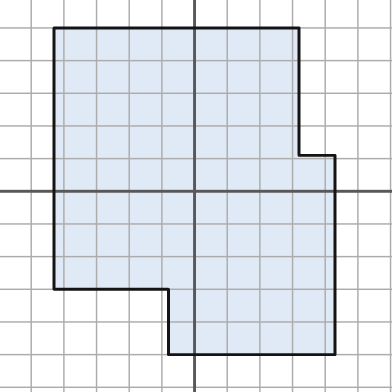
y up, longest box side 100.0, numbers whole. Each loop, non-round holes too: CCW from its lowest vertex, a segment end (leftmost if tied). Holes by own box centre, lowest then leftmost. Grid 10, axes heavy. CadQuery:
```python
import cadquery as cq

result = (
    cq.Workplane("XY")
    .moveTo(-8.0, -50.0)
    .lineTo(43.0, -50.0)
    .lineTo(43.0, 11.0)
    .lineTo(32.0, 11.0)
    .lineTo(32.0, 50.0)
    .lineTo(-43.0, 50.0)
    .lineTo(-43.0, -30.0)
    .lineTo(-8.0, -30.0)
    .close()
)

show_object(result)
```